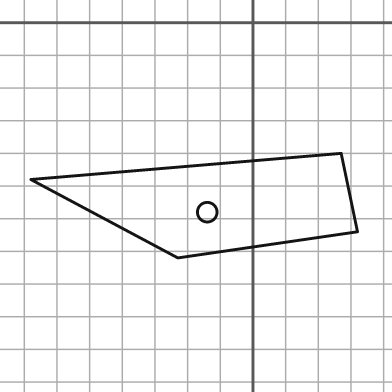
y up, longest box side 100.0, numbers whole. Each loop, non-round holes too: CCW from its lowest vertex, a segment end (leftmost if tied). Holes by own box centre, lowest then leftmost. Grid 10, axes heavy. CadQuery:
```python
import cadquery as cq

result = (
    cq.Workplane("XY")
    .moveTo(-23.0, -72.0)
    .lineTo(32.0, -64.0)
    .lineTo(27.0, -40.0)
    .lineTo(-68.0, -48.0)
    .close()
    .moveTo(-14.0, -58.0)
    .circle(3.0)
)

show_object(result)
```